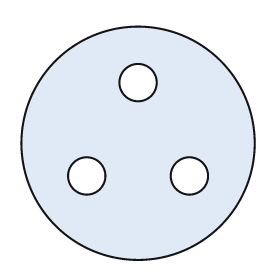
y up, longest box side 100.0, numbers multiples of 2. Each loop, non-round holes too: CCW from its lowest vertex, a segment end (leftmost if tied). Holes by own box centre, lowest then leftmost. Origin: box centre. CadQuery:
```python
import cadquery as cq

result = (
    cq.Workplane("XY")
    .moveTo(0.0, 0.0)
    .circle(50.0)
    .moveTo(-22.0, -14.0)
    .circle(8.0)
    .moveTo(22.0, -14.0)
    .circle(8.0)
    .moveTo(0.0, 26.0)
    .circle(8.0)
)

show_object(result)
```